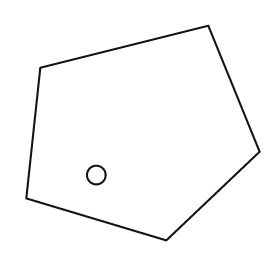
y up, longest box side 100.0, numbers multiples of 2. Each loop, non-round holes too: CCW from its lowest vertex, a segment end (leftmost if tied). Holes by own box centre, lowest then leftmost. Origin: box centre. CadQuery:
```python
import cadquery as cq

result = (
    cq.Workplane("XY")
    .moveTo(10.0, -46.0)
    .lineTo(50.0, -8.0)
    .lineTo(28.0, 46.0)
    .lineTo(-44.0, 28.0)
    .lineTo(-50.0, -28.0)
    .close()
    .moveTo(-20.0, -18.0)
    .circle(4.0)
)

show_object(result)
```